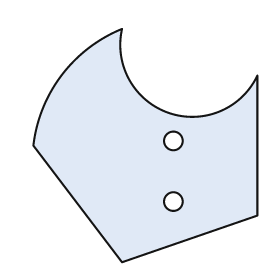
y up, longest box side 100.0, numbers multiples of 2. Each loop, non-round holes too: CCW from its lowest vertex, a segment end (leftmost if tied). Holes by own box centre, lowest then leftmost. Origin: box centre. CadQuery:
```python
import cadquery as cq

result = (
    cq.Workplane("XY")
    .moveTo(-10.0, -50.0)
    .lineTo(48.0, -30.0)
    .lineTo(48.0, 30.0)
    .threePointArc((10.0, 14.0), (-10.0, 50.0))
    .threePointArc((-36.0, 30.0), (-48.0, 0.0))
    .close()
    .moveTo(12.0, -24.0)
    .circle(4.0)
    .moveTo(12.0, 2.0)
    .circle(4.0)
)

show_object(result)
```